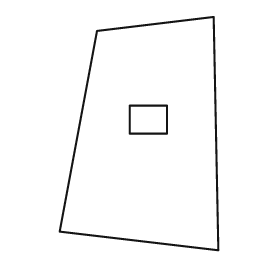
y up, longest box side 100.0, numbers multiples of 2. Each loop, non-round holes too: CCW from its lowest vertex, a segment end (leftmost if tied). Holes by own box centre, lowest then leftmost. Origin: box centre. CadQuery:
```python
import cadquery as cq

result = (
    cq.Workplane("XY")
    .moveTo(34.0, -50.0)
    .lineTo(32.0, 50.0)
    .lineTo(-18.0, 44.0)
    .lineTo(-34.0, -42.0)
    .close()
    .moveTo(-4.0, 0.0)
    .lineTo(12.0, 0.0)
    .lineTo(12.0, 12.0)
    .lineTo(-4.0, 12.0)
    .close()
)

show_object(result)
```